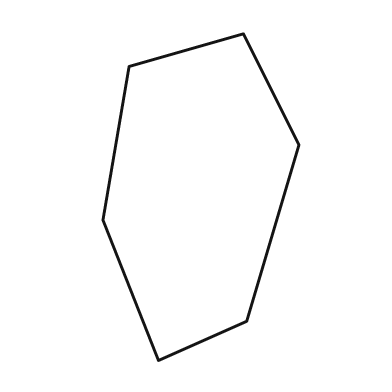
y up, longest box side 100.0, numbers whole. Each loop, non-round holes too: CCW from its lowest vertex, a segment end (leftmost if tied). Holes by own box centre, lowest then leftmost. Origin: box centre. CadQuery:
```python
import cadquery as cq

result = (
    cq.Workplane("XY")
    .moveTo(-13.0, -50.0)
    .lineTo(14.0, -38.0)
    .lineTo(30.0, 16.0)
    .lineTo(13.0, 50.0)
    .lineTo(-22.0, 40.0)
    .lineTo(-30.0, -7.0)
    .close()
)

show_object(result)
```